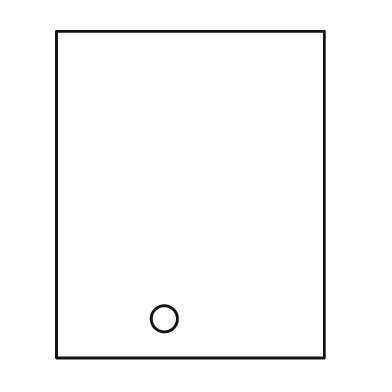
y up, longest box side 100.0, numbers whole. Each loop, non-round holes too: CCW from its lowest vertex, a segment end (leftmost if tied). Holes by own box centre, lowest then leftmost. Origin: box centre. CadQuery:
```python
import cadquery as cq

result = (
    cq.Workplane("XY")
    .moveTo(-41.0, -50.0)
    .lineTo(41.0, -50.0)
    .lineTo(41.0, 50.0)
    .lineTo(-41.0, 50.0)
    .close()
    .moveTo(-8.0, -38.0)
    .circle(4.0)
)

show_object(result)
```